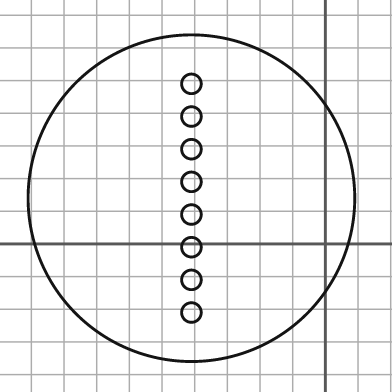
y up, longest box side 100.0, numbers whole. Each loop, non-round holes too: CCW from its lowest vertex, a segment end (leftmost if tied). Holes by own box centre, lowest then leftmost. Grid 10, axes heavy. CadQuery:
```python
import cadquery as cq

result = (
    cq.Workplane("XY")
    .moveTo(-41.0, 14.0)
    .circle(50.0)
    .moveTo(-41.0, -21.0)
    .circle(3.0)
    .moveTo(-41.0, -11.0)
    .circle(3.0)
    .moveTo(-41.0, -1.0)
    .circle(3.0)
    .moveTo(-41.0, 9.0)
    .circle(3.0)
    .moveTo(-41.0, 19.0)
    .circle(3.0)
    .moveTo(-41.0, 29.0)
    .circle(3.0)
    .moveTo(-41.0, 39.0)
    .circle(3.0)
    .moveTo(-41.0, 49.0)
    .circle(3.0)
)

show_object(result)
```